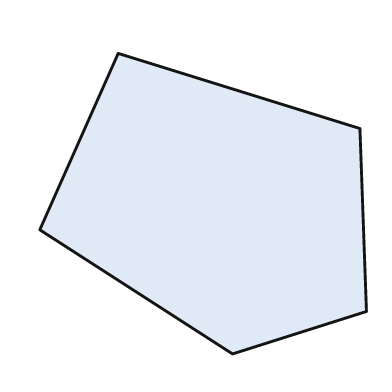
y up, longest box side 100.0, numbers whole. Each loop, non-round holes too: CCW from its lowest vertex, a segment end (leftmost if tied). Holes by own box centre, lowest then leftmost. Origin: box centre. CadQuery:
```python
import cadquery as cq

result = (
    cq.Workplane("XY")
    .moveTo(9.0, -46.0)
    .lineTo(50.0, -33.0)
    .lineTo(48.0, 23.0)
    .lineTo(-26.0, 46.0)
    .lineTo(-50.0, -8.0)
    .close()
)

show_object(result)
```